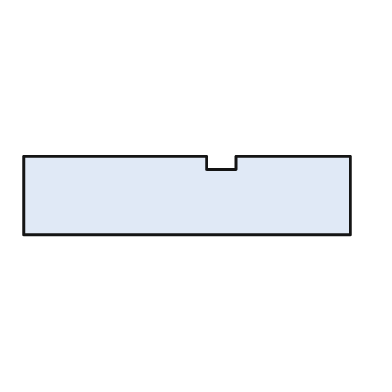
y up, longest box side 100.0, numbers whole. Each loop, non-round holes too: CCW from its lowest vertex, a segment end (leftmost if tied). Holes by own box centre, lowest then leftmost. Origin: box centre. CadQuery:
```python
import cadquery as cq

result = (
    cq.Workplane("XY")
    .moveTo(-50.0, -12.0)
    .lineTo(50.0, -12.0)
    .lineTo(50.0, 12.0)
    .lineTo(15.0, 12.0)
    .lineTo(15.0, 8.0)
    .lineTo(6.0, 8.0)
    .lineTo(6.0, 12.0)
    .lineTo(-50.0, 12.0)
    .close()
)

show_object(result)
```